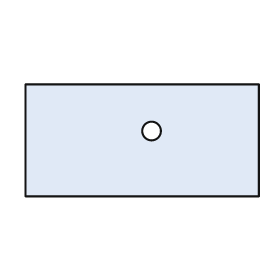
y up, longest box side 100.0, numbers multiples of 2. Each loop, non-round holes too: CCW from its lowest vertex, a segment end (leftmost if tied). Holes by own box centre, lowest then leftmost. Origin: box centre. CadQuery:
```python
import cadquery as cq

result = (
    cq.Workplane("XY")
    .moveTo(-50.0, -24.0)
    .lineTo(50.0, -24.0)
    .lineTo(50.0, 24.0)
    .lineTo(-50.0, 24.0)
    .close()
    .moveTo(4.0, 4.0)
    .circle(4.0)
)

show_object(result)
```